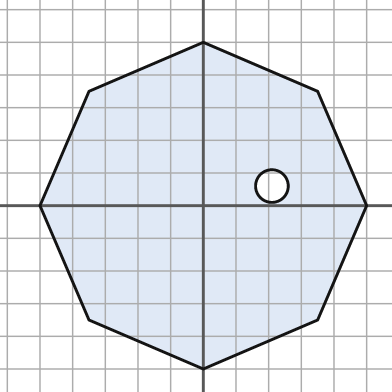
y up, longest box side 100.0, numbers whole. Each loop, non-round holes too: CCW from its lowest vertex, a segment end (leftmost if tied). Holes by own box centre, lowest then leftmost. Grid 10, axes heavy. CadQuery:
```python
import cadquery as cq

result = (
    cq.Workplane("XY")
    .moveTo(0.0, -50.0)
    .lineTo(35.0, -35.0)
    .lineTo(50.0, 0.0)
    .lineTo(35.0, 35.0)
    .lineTo(0.0, 50.0)
    .lineTo(-35.0, 35.0)
    .lineTo(-50.0, 0.0)
    .lineTo(-35.0, -35.0)
    .close()
    .moveTo(21.0, 6.0)
    .circle(5.0)
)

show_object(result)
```